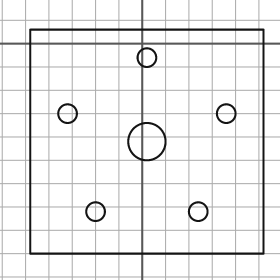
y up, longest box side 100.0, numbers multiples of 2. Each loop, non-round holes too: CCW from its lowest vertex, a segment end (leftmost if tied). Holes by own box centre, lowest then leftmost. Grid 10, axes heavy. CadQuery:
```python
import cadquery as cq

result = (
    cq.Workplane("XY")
    .moveTo(-48.0, -90.0)
    .lineTo(52.0, -90.0)
    .lineTo(52.0, 6.0)
    .lineTo(-48.0, 6.0)
    .close()
    .moveTo(-20.0, -72.0)
    .circle(4.0)
    .moveTo(24.0, -72.0)
    .circle(4.0)
    .moveTo(2.0, -42.0)
    .circle(8.0)
    .moveTo(-32.0, -30.0)
    .circle(4.0)
    .moveTo(36.0, -30.0)
    .circle(4.0)
    .moveTo(2.0, -6.0)
    .circle(4.0)
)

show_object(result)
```